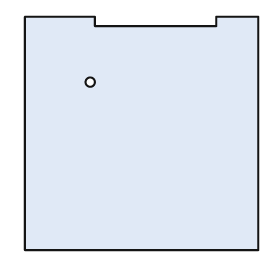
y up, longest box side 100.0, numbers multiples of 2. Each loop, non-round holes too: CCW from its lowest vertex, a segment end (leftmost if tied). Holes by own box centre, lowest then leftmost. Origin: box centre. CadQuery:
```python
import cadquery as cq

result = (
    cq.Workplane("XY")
    .moveTo(-50.0, -50.0)
    .lineTo(50.0, -50.0)
    .lineTo(50.0, 50.0)
    .lineTo(32.0, 50.0)
    .lineTo(32.0, 46.0)
    .lineTo(-20.0, 46.0)
    .lineTo(-20.0, 50.0)
    .lineTo(-50.0, 50.0)
    .close()
    .moveTo(-22.0, 22.0)
    .circle(2.0)
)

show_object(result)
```